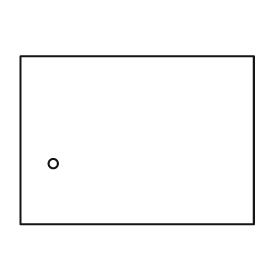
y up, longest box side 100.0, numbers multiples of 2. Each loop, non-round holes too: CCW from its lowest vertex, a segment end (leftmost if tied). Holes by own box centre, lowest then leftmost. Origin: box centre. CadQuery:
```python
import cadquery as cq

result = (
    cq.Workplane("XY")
    .moveTo(-50.0, -36.0)
    .lineTo(50.0, -36.0)
    .lineTo(50.0, 36.0)
    .lineTo(-50.0, 36.0)
    .close()
    .moveTo(-36.0, -10.0)
    .circle(2.0)
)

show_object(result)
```